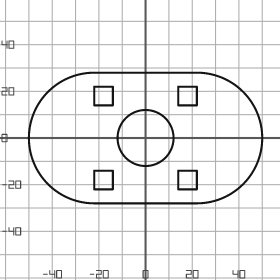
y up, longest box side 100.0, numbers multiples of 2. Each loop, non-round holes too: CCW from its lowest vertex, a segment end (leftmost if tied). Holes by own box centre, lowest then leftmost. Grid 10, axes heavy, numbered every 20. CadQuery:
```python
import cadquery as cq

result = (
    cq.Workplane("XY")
    .moveTo(-22.0, -28.0)
    .lineTo(22.0, -28.0)
    .threePointArc((50.0, 0.0), (22.0, 28.0))
    .lineTo(-22.0, 28.0)
    .threePointArc((-50.0, 0.0), (-22.0, -28.0))
    .close()
    .moveTo(-22.0, -22.0)
    .lineTo(-14.0, -22.0)
    .lineTo(-14.0, -14.0)
    .lineTo(-22.0, -14.0)
    .close()
    .moveTo(14.0, -22.0)
    .lineTo(22.0, -22.0)
    .lineTo(22.0, -14.0)
    .lineTo(14.0, -14.0)
    .close()
    .moveTo(0.0, 0.0)
    .circle(12.0)
    .moveTo(-22.0, 14.0)
    .lineTo(-14.0, 14.0)
    .lineTo(-14.0, 22.0)
    .lineTo(-22.0, 22.0)
    .close()
    .moveTo(14.0, 14.0)
    .lineTo(22.0, 14.0)
    .lineTo(22.0, 22.0)
    .lineTo(14.0, 22.0)
    .close()
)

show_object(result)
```